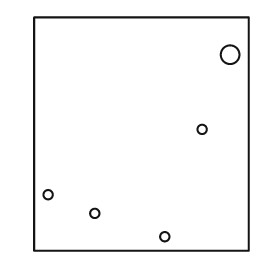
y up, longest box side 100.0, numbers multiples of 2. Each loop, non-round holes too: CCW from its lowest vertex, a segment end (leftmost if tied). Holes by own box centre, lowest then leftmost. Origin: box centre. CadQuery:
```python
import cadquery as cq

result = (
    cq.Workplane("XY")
    .moveTo(-46.0, -50.0)
    .lineTo(46.0, -50.0)
    .lineTo(46.0, 50.0)
    .lineTo(-46.0, 50.0)
    .close()
    .moveTo(10.0, -44.0)
    .circle(2.0)
    .moveTo(-20.0, -34.0)
    .circle(2.0)
    .moveTo(-40.0, -26.0)
    .circle(2.0)
    .moveTo(26.0, 2.0)
    .circle(2.0)
    .moveTo(38.0, 34.0)
    .circle(4.0)
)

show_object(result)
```